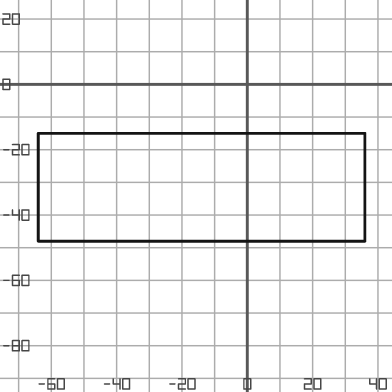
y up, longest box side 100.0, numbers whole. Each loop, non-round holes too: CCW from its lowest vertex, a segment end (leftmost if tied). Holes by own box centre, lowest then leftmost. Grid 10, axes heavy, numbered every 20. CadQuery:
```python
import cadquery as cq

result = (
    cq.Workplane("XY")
    .moveTo(-64.0, -48.0)
    .lineTo(36.0, -48.0)
    .lineTo(36.0, -15.0)
    .lineTo(-64.0, -15.0)
    .close()
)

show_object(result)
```